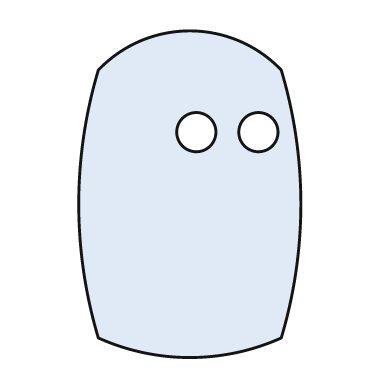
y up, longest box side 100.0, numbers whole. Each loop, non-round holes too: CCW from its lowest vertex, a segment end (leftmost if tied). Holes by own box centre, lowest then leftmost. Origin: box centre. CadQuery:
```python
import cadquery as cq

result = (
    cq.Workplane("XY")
    .moveTo(-28.0, -44.0)
    .threePointArc((0.0, -50.0), (28.0, -44.0))
    .threePointArc((34.0, -3.0), (28.0, 38.0))
    .threePointArc((0.0, 50.0), (-28.0, 38.0))
    .threePointArc((-34.0, -3.0), (-28.0, -44.0))
    .close()
    .moveTo(2.0, 19.0)
    .circle(6.0)
    .moveTo(21.0, 19.0)
    .circle(6.0)
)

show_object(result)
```